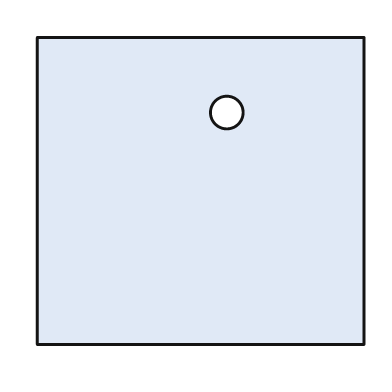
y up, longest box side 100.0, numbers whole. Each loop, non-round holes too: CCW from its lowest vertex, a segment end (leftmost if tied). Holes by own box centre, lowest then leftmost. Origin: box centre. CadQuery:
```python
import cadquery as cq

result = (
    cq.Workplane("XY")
    .moveTo(-50.0, -47.0)
    .lineTo(50.0, -47.0)
    .lineTo(50.0, 47.0)
    .lineTo(-50.0, 47.0)
    .close()
    .moveTo(8.0, 24.0)
    .circle(5.0)
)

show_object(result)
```